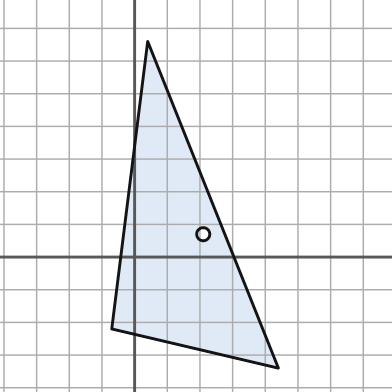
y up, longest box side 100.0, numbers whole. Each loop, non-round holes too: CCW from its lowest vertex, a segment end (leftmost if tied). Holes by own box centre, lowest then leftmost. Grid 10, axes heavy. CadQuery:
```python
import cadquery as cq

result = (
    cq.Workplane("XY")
    .moveTo(44.0, -34.0)
    .lineTo(4.0, 66.0)
    .lineTo(-7.0, -22.0)
    .close()
    .moveTo(21.0, 7.0)
    .circle(2.0)
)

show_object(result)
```